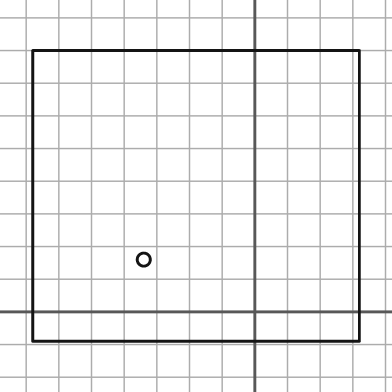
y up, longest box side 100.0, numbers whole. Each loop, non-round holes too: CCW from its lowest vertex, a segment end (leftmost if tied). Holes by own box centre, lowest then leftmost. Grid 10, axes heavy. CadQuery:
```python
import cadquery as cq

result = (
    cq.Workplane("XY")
    .moveTo(-68.0, -9.0)
    .lineTo(32.0, -9.0)
    .lineTo(32.0, 80.0)
    .lineTo(-68.0, 80.0)
    .close()
    .moveTo(-34.0, 16.0)
    .circle(2.0)
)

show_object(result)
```